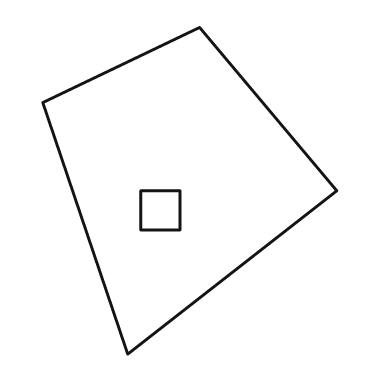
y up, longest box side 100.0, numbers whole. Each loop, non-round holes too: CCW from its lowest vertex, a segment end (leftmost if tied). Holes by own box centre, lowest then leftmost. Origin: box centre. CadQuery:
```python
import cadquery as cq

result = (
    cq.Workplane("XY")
    .moveTo(-19.0, -50.0)
    .lineTo(45.0, 0.0)
    .lineTo(3.0, 50.0)
    .lineTo(-45.0, 27.0)
    .close()
    .moveTo(-15.0, -12.0)
    .lineTo(-3.0, -12.0)
    .lineTo(-3.0, 0.0)
    .lineTo(-15.0, 0.0)
    .close()
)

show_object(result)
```